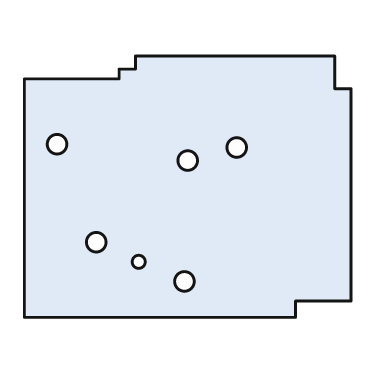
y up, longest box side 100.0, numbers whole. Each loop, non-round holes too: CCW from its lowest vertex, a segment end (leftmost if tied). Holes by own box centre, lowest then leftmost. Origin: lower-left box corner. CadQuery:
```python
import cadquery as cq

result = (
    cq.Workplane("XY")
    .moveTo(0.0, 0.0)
    .lineTo(83.0, 0.0)
    .lineTo(83.0, 5.0)
    .lineTo(100.0, 5.0)
    .lineTo(100.0, 70.0)
    .lineTo(95.0, 70.0)
    .lineTo(95.0, 80.0)
    .lineTo(34.0, 80.0)
    .lineTo(34.0, 76.0)
    .lineTo(29.0, 76.0)
    .lineTo(29.0, 73.0)
    .lineTo(0.0, 73.0)
    .close()
    .moveTo(49.0, 11.0)
    .circle(3.0)
    .moveTo(35.0, 17.0)
    .circle(2.0)
    .moveTo(22.0, 23.0)
    .circle(3.0)
    .moveTo(50.0, 48.0)
    .circle(3.0)
    .moveTo(65.0, 52.0)
    .circle(3.0)
    .moveTo(10.0, 53.0)
    .circle(3.0)
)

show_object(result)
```